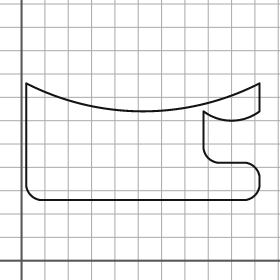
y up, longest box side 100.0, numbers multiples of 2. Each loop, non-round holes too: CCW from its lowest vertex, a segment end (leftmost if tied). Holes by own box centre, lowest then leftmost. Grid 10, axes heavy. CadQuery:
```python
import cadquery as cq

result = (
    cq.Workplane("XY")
    .moveTo(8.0, 26.0)
    .lineTo(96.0, 26.0)
    .threePointArc((100.0, 28.0), (102.0, 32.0))
    .lineTo(102.0, 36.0)
    .threePointArc((100.0, 40.0), (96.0, 42.0))
    .lineTo(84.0, 42.0)
    .threePointArc((80.0, 44.0), (78.0, 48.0))
    .lineTo(78.0, 64.0)
    .threePointArc((90.0, 60.0), (102.0, 64.0))
    .lineTo(102.0, 76.0)
    .threePointArc((52.0, 64.0), (2.0, 76.0))
    .lineTo(2.0, 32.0)
    .threePointArc((4.0, 28.0), (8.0, 26.0))
    .close()
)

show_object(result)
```